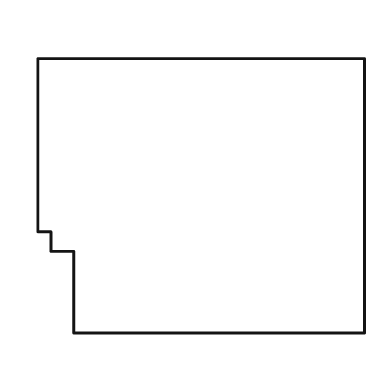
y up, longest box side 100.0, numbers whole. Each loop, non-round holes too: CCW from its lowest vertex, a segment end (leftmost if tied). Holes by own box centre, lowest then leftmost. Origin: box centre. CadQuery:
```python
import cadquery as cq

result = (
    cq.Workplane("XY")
    .moveTo(-39.0, -42.0)
    .lineTo(50.0, -42.0)
    .lineTo(50.0, 42.0)
    .lineTo(-50.0, 42.0)
    .lineTo(-50.0, -11.0)
    .lineTo(-46.0, -11.0)
    .lineTo(-46.0, -17.0)
    .lineTo(-39.0, -17.0)
    .close()
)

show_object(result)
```